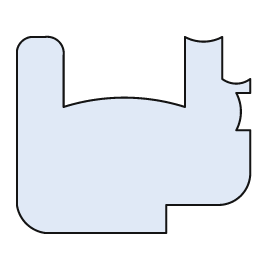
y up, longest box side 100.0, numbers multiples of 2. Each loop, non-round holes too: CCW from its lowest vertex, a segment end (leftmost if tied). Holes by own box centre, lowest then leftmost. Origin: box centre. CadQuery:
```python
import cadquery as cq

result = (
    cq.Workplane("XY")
    .moveTo(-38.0, -42.0)
    .lineTo(14.0, -42.0)
    .lineTo(14.0, -30.0)
    .lineTo(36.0, -30.0)
    .threePointArc((46.0, -26.0), (50.0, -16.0))
    .lineTo(50.0, 2.0)
    .lineTo(44.0, 2.0)
    .threePointArc((46.0, 10.0), (44.0, 18.0))
    .lineTo(50.0, 18.0)
    .lineTo(50.0, 24.0)
    .threePointArc((44.0, 22.0), (38.0, 24.0))
    .lineTo(38.0, 42.0)
    .threePointArc((30.0, 40.0), (22.0, 42.0))
    .lineTo(22.0, 12.0)
    .threePointArc((-4.0, 16.0), (-30.0, 12.0))
    .lineTo(-30.0, 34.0)
    .threePointArc((-32.0, 40.0), (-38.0, 42.0))
    .lineTo(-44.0, 42.0)
    .threePointArc((-48.0, 40.0), (-50.0, 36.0))
    .lineTo(-50.0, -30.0)
    .threePointArc((-46.0, -38.0), (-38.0, -42.0))
    .close()
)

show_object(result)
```